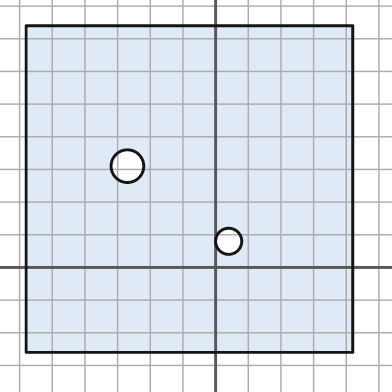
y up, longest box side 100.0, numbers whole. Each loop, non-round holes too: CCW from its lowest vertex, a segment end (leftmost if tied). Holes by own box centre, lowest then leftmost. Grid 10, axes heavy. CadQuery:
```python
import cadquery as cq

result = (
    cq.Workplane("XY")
    .moveTo(-58.0, -26.0)
    .lineTo(42.0, -26.0)
    .lineTo(42.0, 74.0)
    .lineTo(-58.0, 74.0)
    .close()
    .moveTo(4.0, 8.0)
    .circle(4.0)
    .moveTo(-27.0, 31.0)
    .circle(5.0)
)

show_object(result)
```